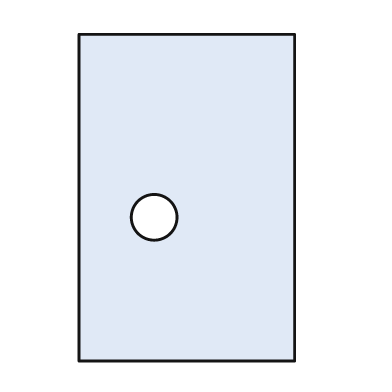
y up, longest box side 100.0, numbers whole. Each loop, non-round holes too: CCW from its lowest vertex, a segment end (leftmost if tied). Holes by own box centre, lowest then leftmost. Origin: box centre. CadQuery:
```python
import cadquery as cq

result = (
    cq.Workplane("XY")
    .moveTo(-33.0, -50.0)
    .lineTo(33.0, -50.0)
    .lineTo(33.0, 50.0)
    .lineTo(-33.0, 50.0)
    .close()
    .moveTo(-10.0, -6.0)
    .circle(7.0)
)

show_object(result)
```